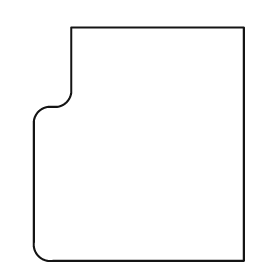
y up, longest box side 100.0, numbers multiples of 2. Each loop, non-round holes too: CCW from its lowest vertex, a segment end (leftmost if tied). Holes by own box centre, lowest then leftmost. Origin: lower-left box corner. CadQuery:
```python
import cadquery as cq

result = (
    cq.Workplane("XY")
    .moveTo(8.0, 0.0)
    .lineTo(90.0, 0.0)
    .lineTo(90.0, 100.0)
    .lineTo(16.0, 100.0)
    .lineTo(16.0, 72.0)
    .threePointArc((14.0, 68.0), (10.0, 66.0))
    .lineTo(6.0, 66.0)
    .threePointArc((2.0, 64.0), (0.0, 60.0))
    .lineTo(0.0, 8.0)
    .threePointArc((2.0, 2.0), (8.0, 0.0))
    .close()
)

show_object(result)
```